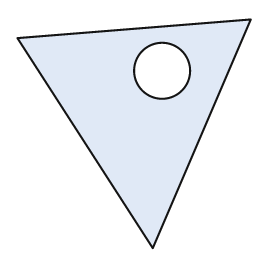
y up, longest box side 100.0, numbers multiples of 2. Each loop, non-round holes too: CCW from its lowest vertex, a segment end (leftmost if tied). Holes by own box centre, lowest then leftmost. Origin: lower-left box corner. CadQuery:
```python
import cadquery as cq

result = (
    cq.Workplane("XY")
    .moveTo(58.0, 0.0)
    .lineTo(100.0, 98.0)
    .lineTo(0.0, 90.0)
    .close()
    .moveTo(62.0, 76.0)
    .circle(12.0)
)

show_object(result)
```